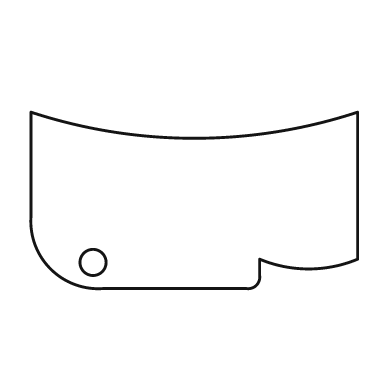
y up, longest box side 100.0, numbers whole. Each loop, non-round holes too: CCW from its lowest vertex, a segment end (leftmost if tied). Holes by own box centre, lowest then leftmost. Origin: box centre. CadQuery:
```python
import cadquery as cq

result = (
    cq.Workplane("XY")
    .moveTo(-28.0, -27.0)
    .lineTo(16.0, -27.0)
    .threePointArc((19.0, -26.0), (20.0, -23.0))
    .lineTo(20.0, -18.0)
    .threePointArc((35.0, -21.0), (50.0, -18.0))
    .lineTo(50.0, 27.0)
    .threePointArc((0.0, 19.0), (-50.0, 27.0))
    .lineTo(-50.0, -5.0)
    .threePointArc((-44.0, -21.0), (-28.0, -27.0))
    .close()
    .moveTo(-31.0, -19.0)
    .circle(4.0)
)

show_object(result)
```